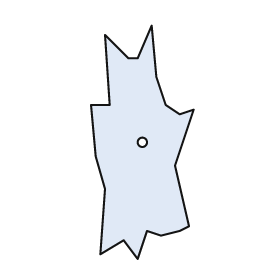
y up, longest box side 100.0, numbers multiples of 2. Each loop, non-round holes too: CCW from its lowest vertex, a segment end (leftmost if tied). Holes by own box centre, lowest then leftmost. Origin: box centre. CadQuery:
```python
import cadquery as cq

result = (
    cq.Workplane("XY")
    .moveTo(-2.0, -50.0)
    .lineTo(2.0, -38.0)
    .lineTo(8.0, -40.0)
    .lineTo(16.0, -38.0)
    .lineTo(20.0, -36.0)
    .lineTo(14.0, -10.0)
    .lineTo(22.0, 14.0)
    .lineTo(16.0, 12.0)
    .lineTo(10.0, 16.0)
    .lineTo(6.0, 28.0)
    .lineTo(4.0, 50.0)
    .lineTo(-2.0, 36.0)
    .lineTo(-6.0, 36.0)
    .lineTo(-16.0, 46.0)
    .lineTo(-14.0, 16.0)
    .lineTo(-22.0, 16.0)
    .lineTo(-20.0, -6.0)
    .lineTo(-16.0, -20.0)
    .lineTo(-18.0, -48.0)
    .lineTo(-8.0, -42.0)
    .close()
    .moveTo(0.0, 0.0)
    .circle(2.0)
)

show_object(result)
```